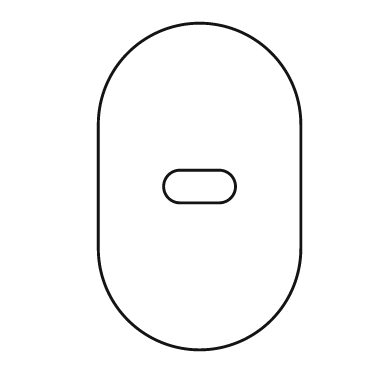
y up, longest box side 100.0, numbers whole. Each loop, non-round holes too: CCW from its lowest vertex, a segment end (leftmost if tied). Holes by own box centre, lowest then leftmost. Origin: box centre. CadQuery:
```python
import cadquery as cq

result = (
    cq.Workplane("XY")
    .moveTo(-31.0, -19.0)
    .threePointArc((0.0, -50.0), (31.0, -19.0))
    .lineTo(31.0, 19.0)
    .threePointArc((0.0, 50.0), (-31.0, 19.0))
    .close()
    .moveTo(-6.0, -5.0)
    .lineTo(6.0, -5.0)
    .threePointArc((11.0, 0.0), (6.0, 5.0))
    .lineTo(-6.0, 5.0)
    .threePointArc((-11.0, 0.0), (-6.0, -5.0))
    .close()
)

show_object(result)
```